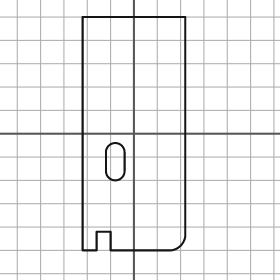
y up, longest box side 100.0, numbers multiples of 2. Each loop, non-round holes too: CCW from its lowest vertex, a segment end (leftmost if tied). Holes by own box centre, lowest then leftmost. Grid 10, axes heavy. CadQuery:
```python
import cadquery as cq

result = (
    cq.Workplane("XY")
    .moveTo(-22.0, -50.0)
    .lineTo(-16.0, -50.0)
    .lineTo(-16.0, -42.0)
    .lineTo(-10.0, -42.0)
    .lineTo(-10.0, -50.0)
    .lineTo(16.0, -50.0)
    .threePointArc((20.0, -48.0), (22.0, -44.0))
    .lineTo(22.0, 50.0)
    .lineTo(-22.0, 50.0)
    .close()
    .moveTo(-12.0, -16.0)
    .threePointArc((-8.0, -20.0), (-4.0, -16.0))
    .lineTo(-4.0, -8.0)
    .threePointArc((-8.0, -4.0), (-12.0, -8.0))
    .close()
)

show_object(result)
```